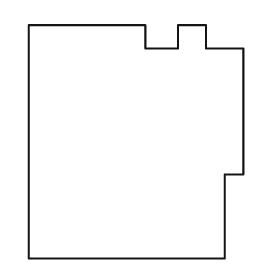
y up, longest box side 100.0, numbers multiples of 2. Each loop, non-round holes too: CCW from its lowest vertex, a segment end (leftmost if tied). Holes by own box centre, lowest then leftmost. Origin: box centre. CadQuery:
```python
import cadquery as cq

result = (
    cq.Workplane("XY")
    .moveTo(-46.0, -50.0)
    .lineTo(38.0, -50.0)
    .lineTo(38.0, -14.0)
    .lineTo(46.0, -14.0)
    .lineTo(46.0, 40.0)
    .lineTo(30.0, 40.0)
    .lineTo(30.0, 50.0)
    .lineTo(18.0, 50.0)
    .lineTo(18.0, 40.0)
    .lineTo(4.0, 40.0)
    .lineTo(4.0, 50.0)
    .lineTo(-46.0, 50.0)
    .close()
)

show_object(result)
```